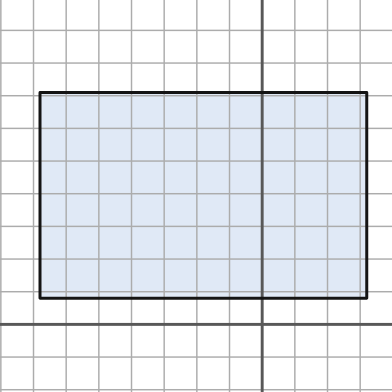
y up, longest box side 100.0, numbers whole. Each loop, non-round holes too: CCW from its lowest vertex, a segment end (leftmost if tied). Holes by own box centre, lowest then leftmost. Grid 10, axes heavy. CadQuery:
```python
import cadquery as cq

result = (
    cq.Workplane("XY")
    .moveTo(-68.0, 8.0)
    .lineTo(32.0, 8.0)
    .lineTo(32.0, 71.0)
    .lineTo(-68.0, 71.0)
    .close()
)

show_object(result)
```